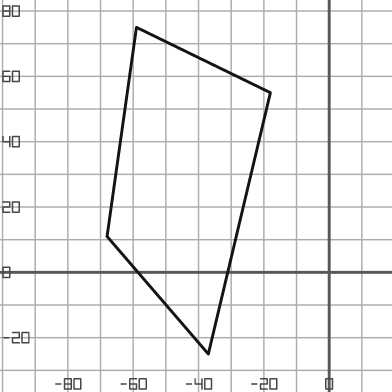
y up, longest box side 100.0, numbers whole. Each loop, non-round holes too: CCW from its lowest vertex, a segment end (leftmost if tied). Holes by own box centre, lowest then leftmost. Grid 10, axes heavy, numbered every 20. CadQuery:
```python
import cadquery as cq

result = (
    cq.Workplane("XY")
    .moveTo(-37.0, -25.0)
    .lineTo(-18.0, 55.0)
    .lineTo(-59.0, 75.0)
    .lineTo(-68.0, 11.0)
    .close()
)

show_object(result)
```